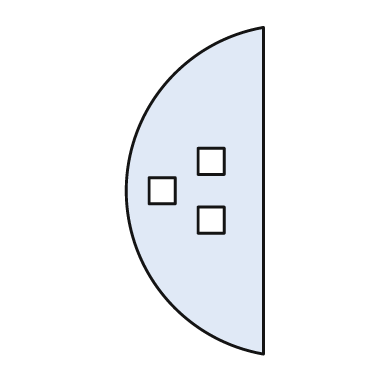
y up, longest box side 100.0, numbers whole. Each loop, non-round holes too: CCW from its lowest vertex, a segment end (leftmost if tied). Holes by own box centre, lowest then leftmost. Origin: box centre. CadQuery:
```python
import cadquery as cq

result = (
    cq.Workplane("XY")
    .moveTo(21.0, -50.0)
    .lineTo(21.0, 50.0)
    .threePointArc((-21.0, 0.0), (21.0, -50.0))
    .close()
    .moveTo(1.0, -13.0)
    .lineTo(9.0, -13.0)
    .lineTo(9.0, -5.0)
    .lineTo(1.0, -5.0)
    .close()
    .moveTo(-14.0, -4.0)
    .lineTo(-6.0, -4.0)
    .lineTo(-6.0, 4.0)
    .lineTo(-14.0, 4.0)
    .close()
    .moveTo(1.0, 5.0)
    .lineTo(9.0, 5.0)
    .lineTo(9.0, 13.0)
    .lineTo(1.0, 13.0)
    .close()
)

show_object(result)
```